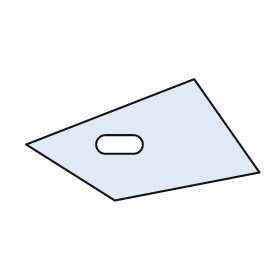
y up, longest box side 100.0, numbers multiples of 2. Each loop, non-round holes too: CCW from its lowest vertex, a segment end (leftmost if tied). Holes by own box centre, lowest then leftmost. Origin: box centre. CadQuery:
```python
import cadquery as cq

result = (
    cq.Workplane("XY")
    .moveTo(-12.0, -26.0)
    .lineTo(50.0, -14.0)
    .lineTo(22.0, 26.0)
    .lineTo(-50.0, -2.0)
    .close()
    .moveTo(-16.0, -6.0)
    .lineTo(-4.0, -6.0)
    .threePointArc((0.0, -2.0), (-4.0, 2.0))
    .lineTo(-16.0, 2.0)
    .threePointArc((-20.0, -2.0), (-16.0, -6.0))
    .close()
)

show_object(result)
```